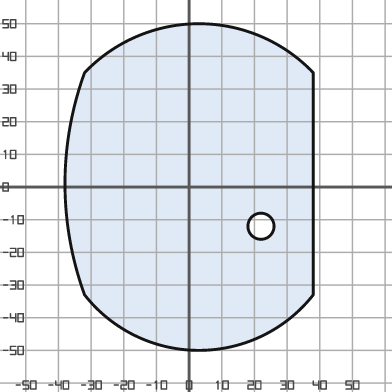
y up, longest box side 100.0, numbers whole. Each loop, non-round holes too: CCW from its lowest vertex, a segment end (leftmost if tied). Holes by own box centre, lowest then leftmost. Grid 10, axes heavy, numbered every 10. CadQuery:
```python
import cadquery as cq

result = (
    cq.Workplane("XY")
    .moveTo(-32.0, -33.0)
    .threePointArc((3.0, -50.0), (38.0, -33.0))
    .lineTo(38.0, 35.0)
    .threePointArc((3.0, 50.0), (-32.0, 35.0))
    .threePointArc((-38.0, 1.0), (-32.0, -33.0))
    .close()
    .moveTo(22.0, -12.0)
    .circle(4.0)
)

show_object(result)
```